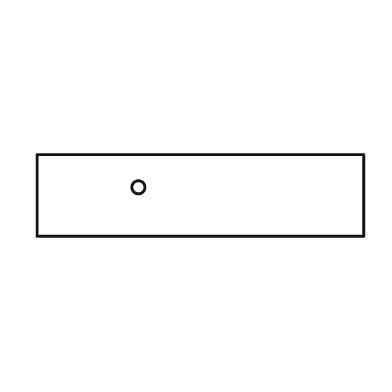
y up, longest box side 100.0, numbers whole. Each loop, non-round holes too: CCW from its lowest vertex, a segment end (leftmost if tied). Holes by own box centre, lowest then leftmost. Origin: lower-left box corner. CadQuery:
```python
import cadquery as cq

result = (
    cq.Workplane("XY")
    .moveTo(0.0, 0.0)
    .lineTo(100.0, 0.0)
    .lineTo(100.0, 25.0)
    .lineTo(0.0, 25.0)
    .close()
    .moveTo(31.0, 15.0)
    .circle(2.0)
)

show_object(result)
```